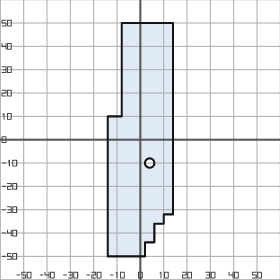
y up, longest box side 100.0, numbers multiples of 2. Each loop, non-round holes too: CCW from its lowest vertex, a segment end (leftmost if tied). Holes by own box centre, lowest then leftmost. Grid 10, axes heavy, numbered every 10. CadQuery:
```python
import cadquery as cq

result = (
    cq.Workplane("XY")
    .moveTo(-14.0, -50.0)
    .lineTo(2.0, -50.0)
    .lineTo(2.0, -44.0)
    .lineTo(6.0, -44.0)
    .lineTo(6.0, -36.0)
    .lineTo(10.0, -36.0)
    .lineTo(10.0, -32.0)
    .lineTo(14.0, -32.0)
    .lineTo(14.0, 50.0)
    .lineTo(-8.0, 50.0)
    .lineTo(-8.0, 10.0)
    .lineTo(-14.0, 10.0)
    .close()
    .moveTo(4.0, -10.0)
    .circle(2.0)
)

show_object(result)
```